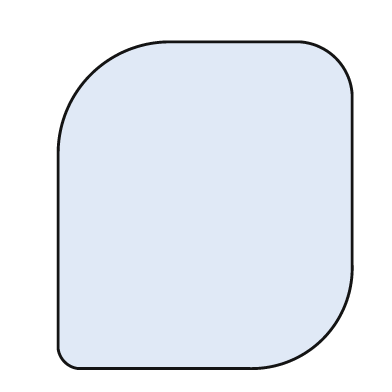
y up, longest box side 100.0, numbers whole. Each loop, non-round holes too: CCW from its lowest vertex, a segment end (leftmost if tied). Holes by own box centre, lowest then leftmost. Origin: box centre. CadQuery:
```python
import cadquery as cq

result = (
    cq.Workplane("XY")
    .moveTo(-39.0, -50.0)
    .lineTo(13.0, -50.0)
    .threePointArc((36.0, -41.0), (45.0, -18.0))
    .lineTo(45.0, 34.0)
    .threePointArc((40.0, 45.0), (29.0, 50.0))
    .lineTo(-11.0, 50.0)
    .threePointArc((-35.0, 40.0), (-45.0, 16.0))
    .lineTo(-45.0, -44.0)
    .threePointArc((-43.0, -48.0), (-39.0, -50.0))
    .close()
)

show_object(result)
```